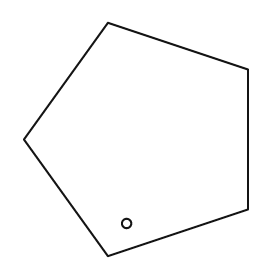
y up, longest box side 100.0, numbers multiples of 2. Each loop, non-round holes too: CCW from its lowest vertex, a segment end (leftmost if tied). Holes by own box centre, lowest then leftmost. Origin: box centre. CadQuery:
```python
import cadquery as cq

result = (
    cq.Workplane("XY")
    .moveTo(-12.0, -50.0)
    .lineTo(48.0, -30.0)
    .lineTo(48.0, 30.0)
    .lineTo(-12.0, 50.0)
    .lineTo(-48.0, 0.0)
    .close()
    .moveTo(-4.0, -36.0)
    .circle(2.0)
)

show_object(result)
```